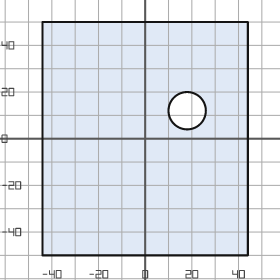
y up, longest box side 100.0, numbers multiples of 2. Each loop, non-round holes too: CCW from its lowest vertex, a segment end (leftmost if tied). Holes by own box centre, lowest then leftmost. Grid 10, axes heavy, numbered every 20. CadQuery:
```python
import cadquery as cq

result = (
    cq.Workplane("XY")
    .moveTo(-44.0, -50.0)
    .lineTo(44.0, -50.0)
    .lineTo(44.0, 50.0)
    .lineTo(-44.0, 50.0)
    .close()
    .moveTo(18.0, 12.0)
    .circle(8.0)
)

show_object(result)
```